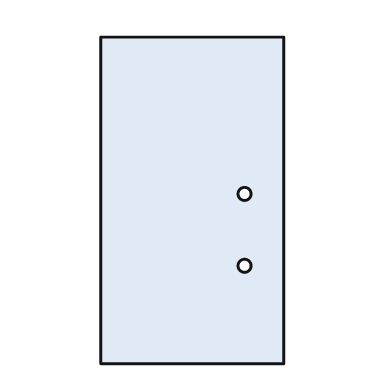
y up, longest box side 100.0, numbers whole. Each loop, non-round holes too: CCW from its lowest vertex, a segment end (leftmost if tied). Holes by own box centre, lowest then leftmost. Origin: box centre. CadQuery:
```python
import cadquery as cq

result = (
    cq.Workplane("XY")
    .moveTo(-28.0, -50.0)
    .lineTo(28.0, -50.0)
    .lineTo(28.0, 50.0)
    .lineTo(-28.0, 50.0)
    .close()
    .moveTo(16.0, -20.0)
    .circle(2.0)
    .moveTo(16.0, 2.0)
    .circle(2.0)
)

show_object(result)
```